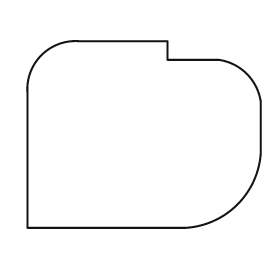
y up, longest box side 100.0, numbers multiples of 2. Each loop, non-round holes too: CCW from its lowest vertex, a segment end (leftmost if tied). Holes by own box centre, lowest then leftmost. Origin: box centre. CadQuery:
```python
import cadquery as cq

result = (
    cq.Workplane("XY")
    .moveTo(-50.0, -40.0)
    .lineTo(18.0, -40.0)
    .threePointArc((40.0, -30.0), (50.0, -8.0))
    .lineTo(50.0, 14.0)
    .threePointArc((44.0, 26.0), (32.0, 32.0))
    .lineTo(10.0, 32.0)
    .lineTo(10.0, 40.0)
    .lineTo(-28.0, 40.0)
    .threePointArc((-44.0, 34.0), (-50.0, 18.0))
    .close()
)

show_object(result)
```